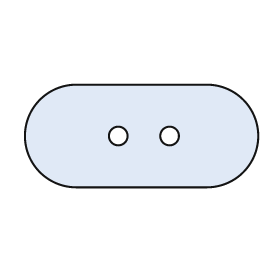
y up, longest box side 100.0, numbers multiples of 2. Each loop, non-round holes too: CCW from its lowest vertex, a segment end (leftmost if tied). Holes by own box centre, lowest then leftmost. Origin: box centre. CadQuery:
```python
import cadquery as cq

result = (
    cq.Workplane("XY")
    .moveTo(-28.0, -22.0)
    .lineTo(28.0, -22.0)
    .threePointArc((50.0, 0.0), (28.0, 22.0))
    .lineTo(-28.0, 22.0)
    .threePointArc((-50.0, 0.0), (-28.0, -22.0))
    .close()
    .moveTo(-10.0, 0.0)
    .circle(4.0)
    .moveTo(12.0, 0.0)
    .circle(4.0)
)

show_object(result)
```